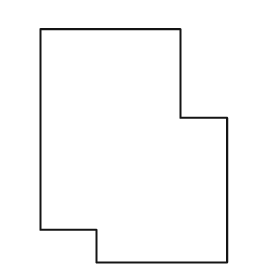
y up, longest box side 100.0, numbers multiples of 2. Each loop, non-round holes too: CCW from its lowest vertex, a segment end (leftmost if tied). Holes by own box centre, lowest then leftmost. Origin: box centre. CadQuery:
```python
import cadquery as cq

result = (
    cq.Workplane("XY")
    .moveTo(-16.0, -50.0)
    .lineTo(40.0, -50.0)
    .lineTo(40.0, 12.0)
    .lineTo(20.0, 12.0)
    .lineTo(20.0, 50.0)
    .lineTo(-40.0, 50.0)
    .lineTo(-40.0, -36.0)
    .lineTo(-16.0, -36.0)
    .close()
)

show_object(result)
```